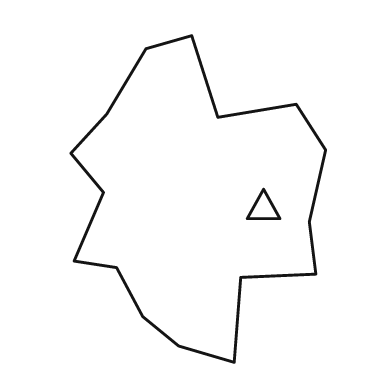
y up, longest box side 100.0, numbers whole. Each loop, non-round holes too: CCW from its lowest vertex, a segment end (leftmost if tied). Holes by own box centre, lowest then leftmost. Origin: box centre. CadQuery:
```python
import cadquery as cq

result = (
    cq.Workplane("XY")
    .moveTo(11.0, -50.0)
    .lineTo(13.0, -24.0)
    .lineTo(36.0, -23.0)
    .lineTo(34.0, -7.0)
    .lineTo(39.0, 15.0)
    .lineTo(30.0, 29.0)
    .lineTo(6.0, 25.0)
    .lineTo(-2.0, 50.0)
    .lineTo(-16.0, 46.0)
    .lineTo(-28.0, 26.0)
    .lineTo(-39.0, 14.0)
    .lineTo(-29.0, 2.0)
    .lineTo(-38.0, -19.0)
    .lineTo(-25.0, -21.0)
    .lineTo(-17.0, -36.0)
    .lineTo(-6.0, -45.0)
    .close()
    .moveTo(15.0, -6.0)
    .lineTo(25.0, -6.0)
    .lineTo(20.0, 3.0)
    .close()
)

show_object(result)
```